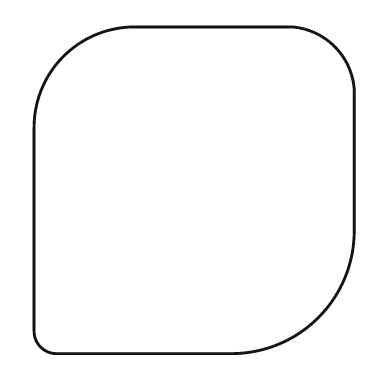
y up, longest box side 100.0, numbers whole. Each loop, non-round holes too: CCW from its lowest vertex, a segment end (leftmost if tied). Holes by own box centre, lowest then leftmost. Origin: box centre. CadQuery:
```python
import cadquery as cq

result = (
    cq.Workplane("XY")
    .moveTo(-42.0, -50.0)
    .lineTo(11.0, -50.0)
    .threePointArc((38.0, -39.0), (49.0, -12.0))
    .lineTo(49.0, 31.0)
    .threePointArc((43.0, 44.0), (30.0, 50.0))
    .lineTo(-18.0, 50.0)
    .threePointArc((-40.0, 41.0), (-49.0, 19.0))
    .lineTo(-49.0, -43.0)
    .threePointArc((-47.0, -48.0), (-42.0, -50.0))
    .close()
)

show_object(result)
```